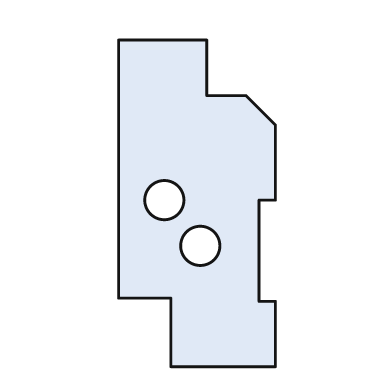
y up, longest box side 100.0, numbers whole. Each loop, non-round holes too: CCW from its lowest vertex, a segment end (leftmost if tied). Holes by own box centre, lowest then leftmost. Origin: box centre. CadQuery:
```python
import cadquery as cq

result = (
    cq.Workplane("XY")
    .moveTo(-8.0, -50.0)
    .lineTo(24.0, -50.0)
    .lineTo(24.0, -30.0)
    .lineTo(19.0, -30.0)
    .lineTo(19.0, 1.0)
    .lineTo(24.0, 1.0)
    .lineTo(24.0, 24.0)
    .lineTo(15.0, 33.0)
    .lineTo(3.0, 33.0)
    .lineTo(3.0, 50.0)
    .lineTo(-24.0, 50.0)
    .lineTo(-24.0, -29.0)
    .lineTo(-8.0, -29.0)
    .close()
    .moveTo(1.0, -13.0)
    .circle(6.0)
    .moveTo(-10.0, 1.0)
    .circle(6.0)
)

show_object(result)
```